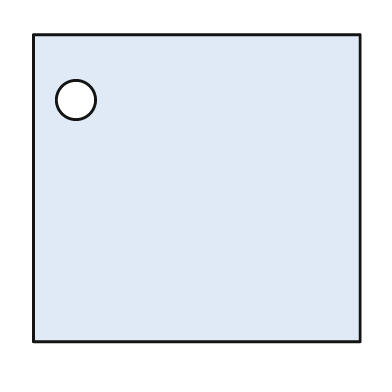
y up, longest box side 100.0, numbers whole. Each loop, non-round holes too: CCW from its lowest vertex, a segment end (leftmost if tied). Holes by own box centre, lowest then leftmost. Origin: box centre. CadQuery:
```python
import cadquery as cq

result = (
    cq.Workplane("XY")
    .moveTo(-50.0, -47.0)
    .lineTo(50.0, -47.0)
    .lineTo(50.0, 47.0)
    .lineTo(-50.0, 47.0)
    .close()
    .moveTo(-37.0, 27.0)
    .circle(6.0)
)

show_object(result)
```